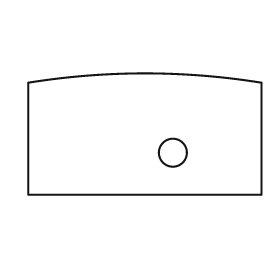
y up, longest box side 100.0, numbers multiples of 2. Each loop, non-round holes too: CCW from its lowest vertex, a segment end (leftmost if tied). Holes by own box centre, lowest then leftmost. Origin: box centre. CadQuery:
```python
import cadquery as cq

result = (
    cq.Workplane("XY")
    .moveTo(-50.0, -26.0)
    .lineTo(50.0, -26.0)
    .lineTo(50.0, 22.0)
    .threePointArc((0.0, 26.0), (-50.0, 22.0))
    .close()
    .moveTo(12.0, -8.0)
    .circle(6.0)
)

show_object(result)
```